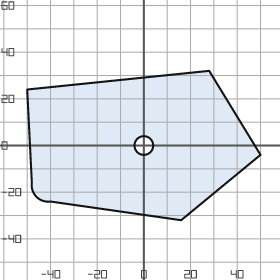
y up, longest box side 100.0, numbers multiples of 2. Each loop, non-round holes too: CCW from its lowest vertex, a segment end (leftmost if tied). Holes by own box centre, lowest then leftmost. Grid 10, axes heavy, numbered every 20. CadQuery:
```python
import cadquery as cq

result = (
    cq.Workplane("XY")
    .moveTo(16.0, -32.0)
    .lineTo(50.0, -4.0)
    .lineTo(28.0, 32.0)
    .lineTo(-50.0, 24.0)
    .lineTo(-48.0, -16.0)
    .threePointArc((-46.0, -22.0), (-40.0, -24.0))
    .close()
    .moveTo(0.0, 0.0)
    .circle(4.0)
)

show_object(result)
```